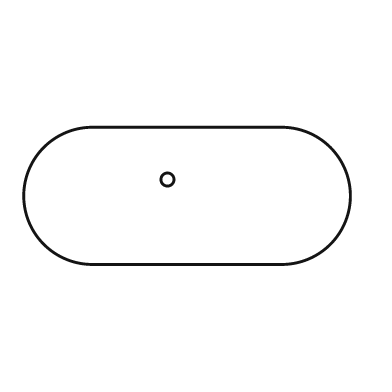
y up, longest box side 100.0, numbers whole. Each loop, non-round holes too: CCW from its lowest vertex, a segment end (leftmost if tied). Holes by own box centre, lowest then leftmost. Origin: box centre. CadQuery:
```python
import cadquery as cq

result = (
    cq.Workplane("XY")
    .moveTo(-29.0, -21.0)
    .lineTo(29.0, -21.0)
    .threePointArc((50.0, 0.0), (29.0, 21.0))
    .lineTo(-29.0, 21.0)
    .threePointArc((-50.0, 0.0), (-29.0, -21.0))
    .close()
    .moveTo(-6.0, 5.0)
    .circle(2.0)
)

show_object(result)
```